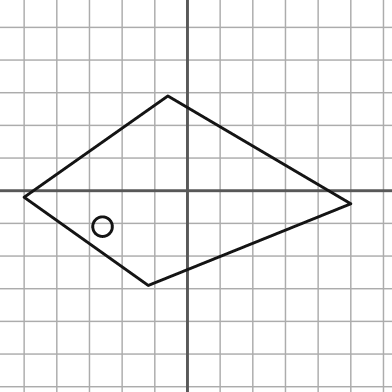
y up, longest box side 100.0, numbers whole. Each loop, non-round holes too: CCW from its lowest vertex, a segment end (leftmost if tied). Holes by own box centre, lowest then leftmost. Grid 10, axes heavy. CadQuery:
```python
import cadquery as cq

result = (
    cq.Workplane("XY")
    .moveTo(-12.0, -29.0)
    .lineTo(50.0, -4.0)
    .lineTo(-6.0, 29.0)
    .lineTo(-50.0, -2.0)
    .close()
    .moveTo(-26.0, -11.0)
    .circle(3.0)
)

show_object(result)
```